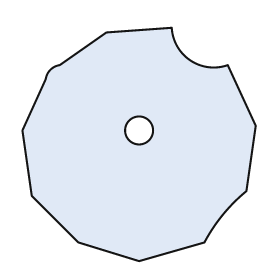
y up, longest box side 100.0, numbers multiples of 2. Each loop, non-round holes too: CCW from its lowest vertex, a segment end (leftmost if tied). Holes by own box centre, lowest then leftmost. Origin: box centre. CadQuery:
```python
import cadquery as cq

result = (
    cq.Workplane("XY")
    .moveTo(0.0, -50.0)
    .lineTo(28.0, -42.0)
    .threePointArc((36.0, -30.0), (46.0, -20.0))
    .lineTo(50.0, 8.0)
    .lineTo(38.0, 34.0)
    .threePointArc((22.0, 36.0), (14.0, 50.0))
    .lineTo(-14.0, 48.0)
    .lineTo(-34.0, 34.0)
    .threePointArc((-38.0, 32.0), (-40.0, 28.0))
    .lineTo(-50.0, 6.0)
    .lineTo(-46.0, -22.0)
    .lineTo(-26.0, -42.0)
    .close()
    .moveTo(0.0, 6.0)
    .circle(6.0)
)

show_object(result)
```